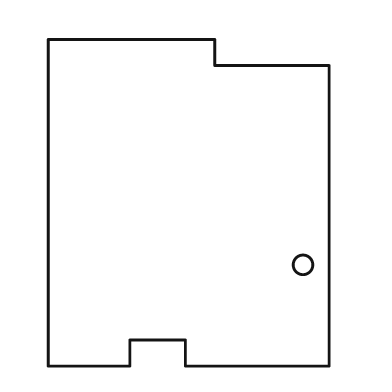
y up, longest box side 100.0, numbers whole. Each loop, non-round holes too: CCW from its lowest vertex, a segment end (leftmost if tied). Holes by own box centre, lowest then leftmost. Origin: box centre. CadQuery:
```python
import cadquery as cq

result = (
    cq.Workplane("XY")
    .moveTo(-43.0, -50.0)
    .lineTo(-18.0, -50.0)
    .lineTo(-18.0, -42.0)
    .lineTo(-1.0, -42.0)
    .lineTo(-1.0, -50.0)
    .lineTo(43.0, -50.0)
    .lineTo(43.0, 42.0)
    .lineTo(8.0, 42.0)
    .lineTo(8.0, 50.0)
    .lineTo(-43.0, 50.0)
    .close()
    .moveTo(35.0, -19.0)
    .circle(3.0)
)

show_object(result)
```